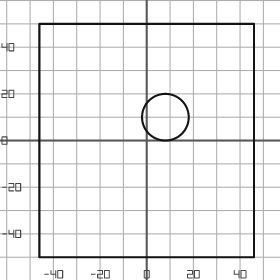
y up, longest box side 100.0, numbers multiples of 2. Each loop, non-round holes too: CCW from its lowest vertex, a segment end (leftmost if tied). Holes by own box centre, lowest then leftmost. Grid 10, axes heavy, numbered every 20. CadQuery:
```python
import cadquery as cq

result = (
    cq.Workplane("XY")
    .moveTo(-46.0, -50.0)
    .lineTo(46.0, -50.0)
    .lineTo(46.0, 50.0)
    .lineTo(-46.0, 50.0)
    .close()
    .moveTo(8.0, 10.0)
    .circle(10.0)
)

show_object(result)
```